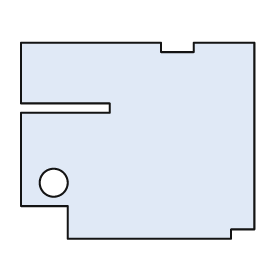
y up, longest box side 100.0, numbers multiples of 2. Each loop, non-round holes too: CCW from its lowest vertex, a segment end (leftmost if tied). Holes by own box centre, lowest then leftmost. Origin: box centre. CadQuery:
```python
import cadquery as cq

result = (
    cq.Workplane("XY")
    .moveTo(-30.0, -42.0)
    .lineTo(40.0, -42.0)
    .lineTo(40.0, -38.0)
    .lineTo(50.0, -38.0)
    .lineTo(50.0, 42.0)
    .lineTo(24.0, 42.0)
    .lineTo(24.0, 38.0)
    .lineTo(10.0, 38.0)
    .lineTo(10.0, 42.0)
    .lineTo(-50.0, 42.0)
    .lineTo(-50.0, 16.0)
    .lineTo(-12.0, 16.0)
    .lineTo(-12.0, 12.0)
    .lineTo(-50.0, 12.0)
    .lineTo(-50.0, -28.0)
    .lineTo(-30.0, -28.0)
    .close()
    .moveTo(-36.0, -18.0)
    .circle(6.0)
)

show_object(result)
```